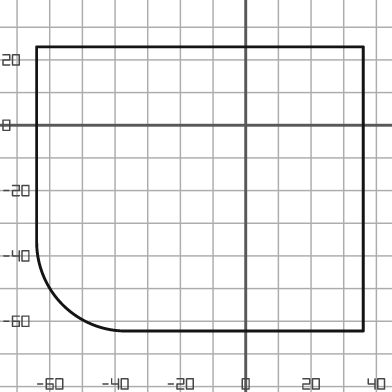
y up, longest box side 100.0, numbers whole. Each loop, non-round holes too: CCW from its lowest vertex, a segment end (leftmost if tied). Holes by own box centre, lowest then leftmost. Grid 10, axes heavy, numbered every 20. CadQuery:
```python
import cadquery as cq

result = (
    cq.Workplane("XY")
    .moveTo(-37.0, -63.0)
    .lineTo(36.0, -63.0)
    .lineTo(36.0, 24.0)
    .lineTo(-64.0, 24.0)
    .lineTo(-64.0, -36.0)
    .threePointArc((-56.0, -55.0), (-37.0, -63.0))
    .close()
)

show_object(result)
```